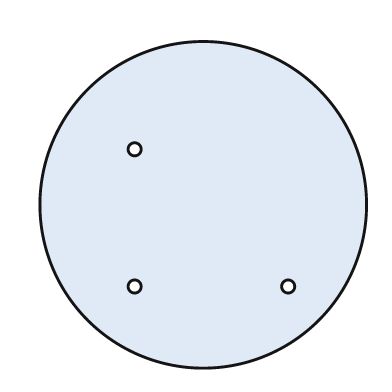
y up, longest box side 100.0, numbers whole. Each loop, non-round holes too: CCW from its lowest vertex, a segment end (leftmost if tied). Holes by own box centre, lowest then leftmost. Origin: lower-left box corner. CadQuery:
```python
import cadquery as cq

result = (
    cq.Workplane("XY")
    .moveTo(50.0, 50.0)
    .circle(50.0)
    .moveTo(29.0, 25.0)
    .circle(2.0)
    .moveTo(76.0, 25.0)
    .circle(2.0)
    .moveTo(29.0, 67.0)
    .circle(2.0)
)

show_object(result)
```